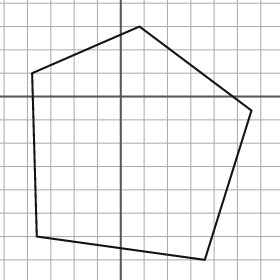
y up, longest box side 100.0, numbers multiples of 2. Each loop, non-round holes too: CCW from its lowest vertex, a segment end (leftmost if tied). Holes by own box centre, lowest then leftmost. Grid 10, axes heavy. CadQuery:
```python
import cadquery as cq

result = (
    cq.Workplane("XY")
    .moveTo(36.0, -70.0)
    .lineTo(56.0, -6.0)
    .lineTo(8.0, 30.0)
    .lineTo(-38.0, 10.0)
    .lineTo(-36.0, -60.0)
    .close()
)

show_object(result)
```